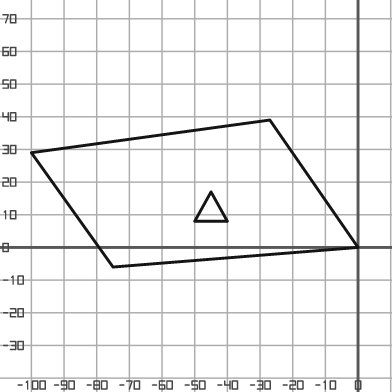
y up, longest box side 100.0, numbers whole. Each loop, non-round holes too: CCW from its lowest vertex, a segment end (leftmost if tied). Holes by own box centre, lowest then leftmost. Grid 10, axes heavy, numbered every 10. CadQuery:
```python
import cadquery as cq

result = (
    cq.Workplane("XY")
    .moveTo(-75.0, -6.0)
    .lineTo(0.0, 0.0)
    .lineTo(-27.0, 39.0)
    .lineTo(-100.0, 29.0)
    .close()
    .moveTo(-50.0, 8.0)
    .lineTo(-40.0, 8.0)
    .lineTo(-45.0, 17.0)
    .close()
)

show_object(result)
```